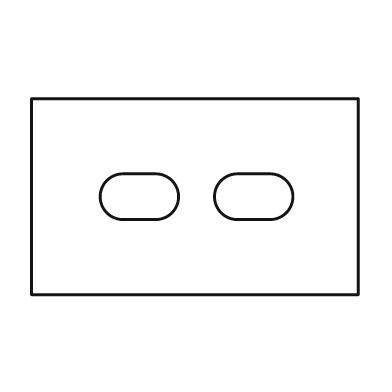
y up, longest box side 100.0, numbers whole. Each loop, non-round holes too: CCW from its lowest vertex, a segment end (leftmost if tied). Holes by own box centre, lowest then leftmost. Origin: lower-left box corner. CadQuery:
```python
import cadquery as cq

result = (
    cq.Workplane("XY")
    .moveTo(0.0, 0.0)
    .lineTo(100.0, 0.0)
    .lineTo(100.0, 60.0)
    .lineTo(0.0, 60.0)
    .close()
    .moveTo(28.0, 23.0)
    .lineTo(38.0, 23.0)
    .threePointArc((45.0, 30.0), (38.0, 37.0))
    .lineTo(28.0, 37.0)
    .threePointArc((21.0, 30.0), (28.0, 23.0))
    .close()
    .moveTo(63.0, 23.0)
    .lineTo(73.0, 23.0)
    .threePointArc((80.0, 30.0), (73.0, 37.0))
    .lineTo(63.0, 37.0)
    .threePointArc((56.0, 30.0), (63.0, 23.0))
    .close()
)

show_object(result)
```